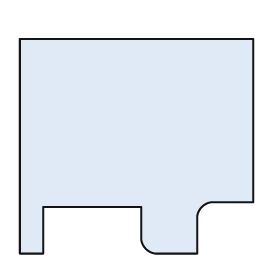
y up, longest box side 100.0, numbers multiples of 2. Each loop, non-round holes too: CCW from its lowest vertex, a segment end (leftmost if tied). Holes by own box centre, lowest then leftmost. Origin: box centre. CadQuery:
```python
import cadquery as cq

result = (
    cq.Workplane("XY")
    .moveTo(-50.0, -46.0)
    .lineTo(-40.0, -46.0)
    .lineTo(-40.0, -26.0)
    .lineTo(2.0, -26.0)
    .lineTo(2.0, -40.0)
    .threePointArc((4.0, -44.0), (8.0, -46.0))
    .lineTo(26.0, -46.0)
    .lineTo(26.0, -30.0)
    .threePointArc((28.0, -26.0), (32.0, -24.0))
    .lineTo(50.0, -24.0)
    .lineTo(50.0, 46.0)
    .lineTo(-50.0, 46.0)
    .close()
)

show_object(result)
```